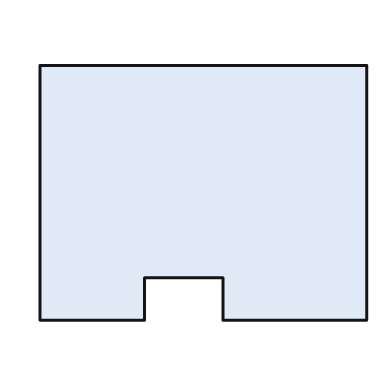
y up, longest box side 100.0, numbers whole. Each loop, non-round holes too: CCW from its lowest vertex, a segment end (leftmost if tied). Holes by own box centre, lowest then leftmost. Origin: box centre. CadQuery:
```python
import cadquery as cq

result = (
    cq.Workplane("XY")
    .moveTo(-50.0, -39.0)
    .lineTo(-18.0, -39.0)
    .lineTo(-18.0, -26.0)
    .lineTo(6.0, -26.0)
    .lineTo(6.0, -39.0)
    .lineTo(50.0, -39.0)
    .lineTo(50.0, 39.0)
    .lineTo(-50.0, 39.0)
    .close()
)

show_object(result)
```